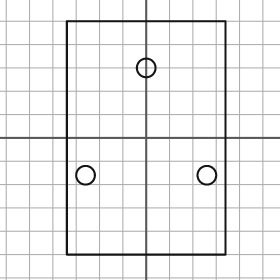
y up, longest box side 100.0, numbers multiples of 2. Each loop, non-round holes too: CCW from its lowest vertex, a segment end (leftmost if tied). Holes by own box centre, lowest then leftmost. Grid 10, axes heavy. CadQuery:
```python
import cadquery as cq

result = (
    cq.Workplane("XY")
    .moveTo(-34.0, -50.0)
    .lineTo(34.0, -50.0)
    .lineTo(34.0, 50.0)
    .lineTo(-34.0, 50.0)
    .close()
    .moveTo(-26.0, -16.0)
    .circle(4.0)
    .moveTo(26.0, -16.0)
    .circle(4.0)
    .moveTo(0.0, 30.0)
    .circle(4.0)
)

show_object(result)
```